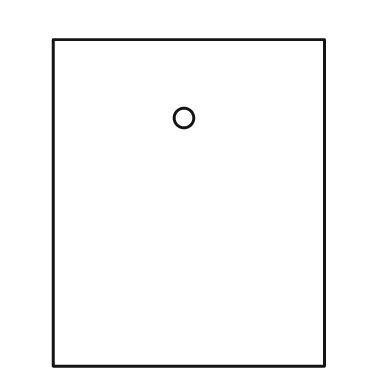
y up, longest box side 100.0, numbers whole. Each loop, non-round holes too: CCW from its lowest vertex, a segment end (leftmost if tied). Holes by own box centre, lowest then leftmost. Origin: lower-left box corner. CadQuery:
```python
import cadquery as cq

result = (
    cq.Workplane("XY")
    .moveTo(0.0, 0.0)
    .lineTo(83.0, 0.0)
    .lineTo(83.0, 100.0)
    .lineTo(0.0, 100.0)
    .close()
    .moveTo(40.0, 76.0)
    .circle(3.0)
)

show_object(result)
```